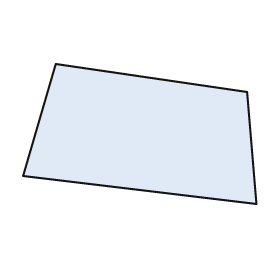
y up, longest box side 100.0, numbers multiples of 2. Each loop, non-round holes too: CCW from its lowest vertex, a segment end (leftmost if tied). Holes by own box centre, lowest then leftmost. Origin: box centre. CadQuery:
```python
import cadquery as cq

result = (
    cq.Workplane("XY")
    .moveTo(50.0, -30.0)
    .lineTo(46.0, 18.0)
    .lineTo(-36.0, 30.0)
    .lineTo(-50.0, -18.0)
    .close()
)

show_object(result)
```